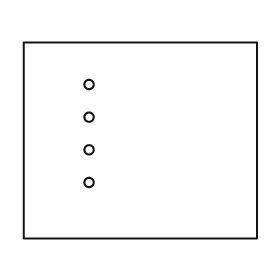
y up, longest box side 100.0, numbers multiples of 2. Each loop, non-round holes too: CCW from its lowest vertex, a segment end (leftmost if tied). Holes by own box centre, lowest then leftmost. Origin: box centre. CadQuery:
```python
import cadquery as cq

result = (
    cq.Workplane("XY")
    .moveTo(-50.0, -42.0)
    .lineTo(50.0, -42.0)
    .lineTo(50.0, 42.0)
    .lineTo(-50.0, 42.0)
    .close()
    .moveTo(-22.0, -18.0)
    .circle(2.0)
    .moveTo(-22.0, -4.0)
    .circle(2.0)
    .moveTo(-22.0, 10.0)
    .circle(2.0)
    .moveTo(-22.0, 24.0)
    .circle(2.0)
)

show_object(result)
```